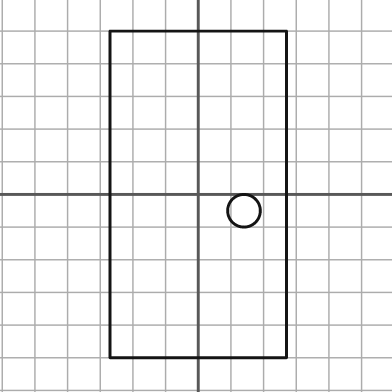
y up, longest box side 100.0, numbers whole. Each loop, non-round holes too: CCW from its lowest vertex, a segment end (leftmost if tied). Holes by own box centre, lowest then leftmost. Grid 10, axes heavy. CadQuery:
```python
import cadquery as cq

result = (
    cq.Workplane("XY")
    .moveTo(-27.0, -50.0)
    .lineTo(27.0, -50.0)
    .lineTo(27.0, 50.0)
    .lineTo(-27.0, 50.0)
    .close()
    .moveTo(14.0, -5.0)
    .circle(5.0)
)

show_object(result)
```